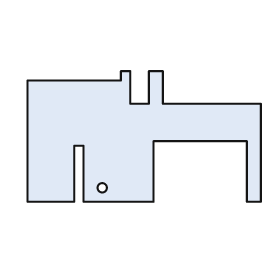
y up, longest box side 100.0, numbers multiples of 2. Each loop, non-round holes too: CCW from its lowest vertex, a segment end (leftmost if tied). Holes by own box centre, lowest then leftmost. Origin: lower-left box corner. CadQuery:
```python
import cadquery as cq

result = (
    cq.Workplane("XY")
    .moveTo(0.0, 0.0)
    .lineTo(20.0, 0.0)
    .lineTo(20.0, 24.0)
    .lineTo(24.0, 24.0)
    .lineTo(24.0, 0.0)
    .lineTo(54.0, 0.0)
    .lineTo(54.0, 26.0)
    .lineTo(94.0, 26.0)
    .lineTo(94.0, 0.0)
    .lineTo(100.0, 0.0)
    .lineTo(100.0, 42.0)
    .lineTo(58.0, 42.0)
    .lineTo(58.0, 56.0)
    .lineTo(52.0, 56.0)
    .lineTo(52.0, 42.0)
    .lineTo(44.0, 42.0)
    .lineTo(44.0, 56.0)
    .lineTo(40.0, 56.0)
    .lineTo(40.0, 52.0)
    .lineTo(0.0, 52.0)
    .close()
    .moveTo(32.0, 6.0)
    .circle(2.0)
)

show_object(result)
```